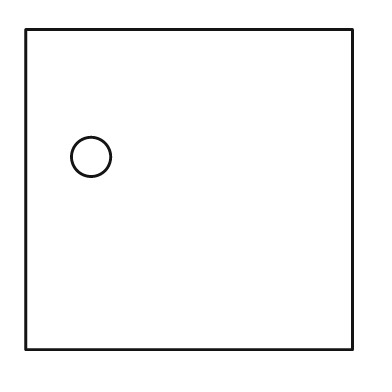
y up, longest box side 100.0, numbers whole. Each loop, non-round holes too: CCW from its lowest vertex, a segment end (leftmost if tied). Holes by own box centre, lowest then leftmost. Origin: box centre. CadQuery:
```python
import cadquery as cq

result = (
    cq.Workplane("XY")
    .moveTo(-50.0, -49.0)
    .lineTo(50.0, -49.0)
    .lineTo(50.0, 49.0)
    .lineTo(-50.0, 49.0)
    .close()
    .moveTo(-30.0, 10.0)
    .circle(6.0)
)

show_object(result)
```